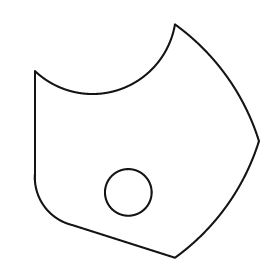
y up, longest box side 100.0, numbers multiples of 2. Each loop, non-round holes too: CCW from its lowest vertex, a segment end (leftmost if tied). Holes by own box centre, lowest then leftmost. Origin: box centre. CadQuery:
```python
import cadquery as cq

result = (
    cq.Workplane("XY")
    .moveTo(12.0, -50.0)
    .threePointArc((34.0, -28.0), (48.0, 0.0))
    .threePointArc((34.0, 28.0), (12.0, 50.0))
    .threePointArc((-12.0, 22.0), (-48.0, 30.0))
    .lineTo(-48.0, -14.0)
    .threePointArc((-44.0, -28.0), (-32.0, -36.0))
    .close()
    .moveTo(-8.0, -22.0)
    .circle(10.0)
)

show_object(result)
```